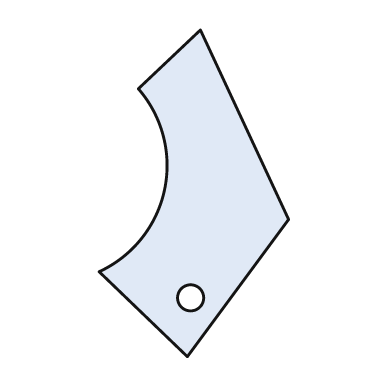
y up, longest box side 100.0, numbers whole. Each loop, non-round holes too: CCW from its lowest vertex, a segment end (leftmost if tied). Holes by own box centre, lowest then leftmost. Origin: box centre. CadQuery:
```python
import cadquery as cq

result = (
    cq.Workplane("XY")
    .moveTo(-2.0, -50.0)
    .lineTo(29.0, -8.0)
    .lineTo(2.0, 50.0)
    .lineTo(-17.0, 32.0)
    .threePointArc((-9.0, 1.0), (-29.0, -24.0))
    .close()
    .moveTo(-1.0, -32.0)
    .circle(4.0)
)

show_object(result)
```